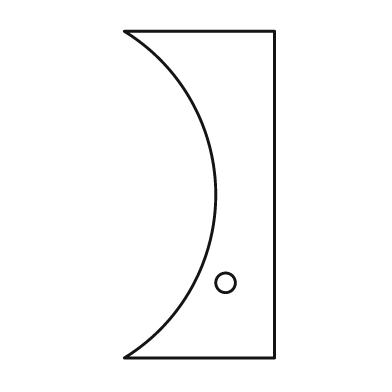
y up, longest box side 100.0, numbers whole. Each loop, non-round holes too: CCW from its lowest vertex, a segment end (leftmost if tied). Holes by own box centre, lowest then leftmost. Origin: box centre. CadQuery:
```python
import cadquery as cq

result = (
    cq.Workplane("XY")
    .moveTo(-23.0, -50.0)
    .lineTo(23.0, -50.0)
    .lineTo(23.0, 50.0)
    .lineTo(-23.0, 50.0)
    .threePointArc((5.0, 0.0), (-23.0, -50.0))
    .close()
    .moveTo(8.0, -27.0)
    .circle(3.0)
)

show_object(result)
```